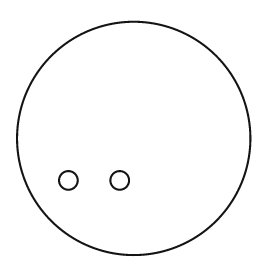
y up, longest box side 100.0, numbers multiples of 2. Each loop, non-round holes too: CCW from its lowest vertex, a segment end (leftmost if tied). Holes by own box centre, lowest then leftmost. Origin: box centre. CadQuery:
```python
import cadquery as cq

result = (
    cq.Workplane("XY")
    .moveTo(0.0, 0.0)
    .circle(50.0)
    .moveTo(-28.0, -18.0)
    .circle(4.0)
    .moveTo(-6.0, -18.0)
    .circle(4.0)
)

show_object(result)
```